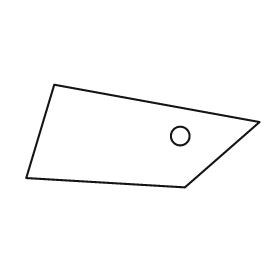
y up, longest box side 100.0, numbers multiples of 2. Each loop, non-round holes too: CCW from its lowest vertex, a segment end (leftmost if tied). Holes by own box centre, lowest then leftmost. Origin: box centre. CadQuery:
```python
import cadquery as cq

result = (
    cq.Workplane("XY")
    .moveTo(18.0, -22.0)
    .lineTo(50.0, 6.0)
    .lineTo(-38.0, 22.0)
    .lineTo(-50.0, -18.0)
    .close()
    .moveTo(16.0, 0.0)
    .circle(4.0)
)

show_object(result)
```